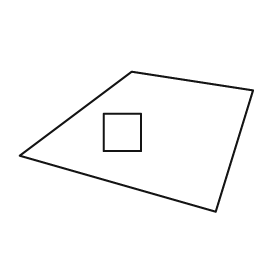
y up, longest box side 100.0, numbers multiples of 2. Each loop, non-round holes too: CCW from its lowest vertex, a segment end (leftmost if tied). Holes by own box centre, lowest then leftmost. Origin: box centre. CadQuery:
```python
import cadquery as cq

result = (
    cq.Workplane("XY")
    .moveTo(34.0, -30.0)
    .lineTo(50.0, 22.0)
    .lineTo(-2.0, 30.0)
    .lineTo(-50.0, -6.0)
    .close()
    .moveTo(-14.0, -4.0)
    .lineTo(2.0, -4.0)
    .lineTo(2.0, 12.0)
    .lineTo(-14.0, 12.0)
    .close()
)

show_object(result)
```